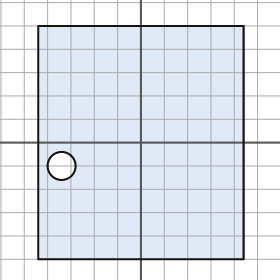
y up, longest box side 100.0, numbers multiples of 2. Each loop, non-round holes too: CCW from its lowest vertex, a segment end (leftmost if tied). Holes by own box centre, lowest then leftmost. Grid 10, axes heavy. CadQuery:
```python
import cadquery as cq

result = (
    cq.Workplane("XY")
    .moveTo(-44.0, -50.0)
    .lineTo(44.0, -50.0)
    .lineTo(44.0, 50.0)
    .lineTo(-44.0, 50.0)
    .close()
    .moveTo(-34.0, -10.0)
    .circle(6.0)
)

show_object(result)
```